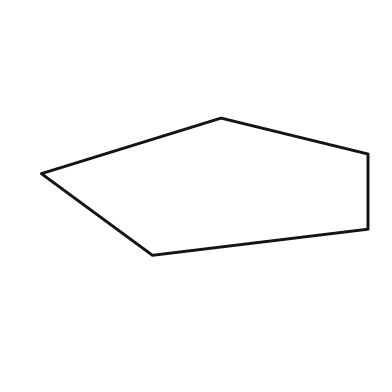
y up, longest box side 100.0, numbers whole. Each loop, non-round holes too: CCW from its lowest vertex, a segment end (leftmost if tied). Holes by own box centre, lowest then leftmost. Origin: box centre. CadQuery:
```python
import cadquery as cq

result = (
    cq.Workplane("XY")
    .moveTo(-16.0, -21.0)
    .lineTo(50.0, -13.0)
    .lineTo(50.0, 10.0)
    .lineTo(5.0, 21.0)
    .lineTo(-50.0, 4.0)
    .close()
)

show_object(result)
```